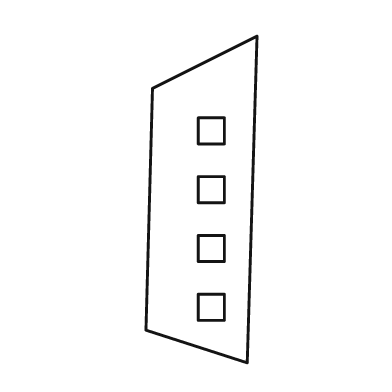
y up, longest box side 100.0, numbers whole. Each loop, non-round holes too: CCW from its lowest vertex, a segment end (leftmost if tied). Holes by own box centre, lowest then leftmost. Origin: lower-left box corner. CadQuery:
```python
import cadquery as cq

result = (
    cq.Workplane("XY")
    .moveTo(31.0, 0.0)
    .lineTo(34.0, 100.0)
    .lineTo(2.0, 84.0)
    .lineTo(0.0, 10.0)
    .close()
    .moveTo(16.0, 13.0)
    .lineTo(24.0, 13.0)
    .lineTo(24.0, 21.0)
    .lineTo(16.0, 21.0)
    .close()
    .moveTo(16.0, 31.0)
    .lineTo(24.0, 31.0)
    .lineTo(24.0, 39.0)
    .lineTo(16.0, 39.0)
    .close()
    .moveTo(16.0, 49.0)
    .lineTo(24.0, 49.0)
    .lineTo(24.0, 57.0)
    .lineTo(16.0, 57.0)
    .close()
    .moveTo(16.0, 67.0)
    .lineTo(24.0, 67.0)
    .lineTo(24.0, 75.0)
    .lineTo(16.0, 75.0)
    .close()
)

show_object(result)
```